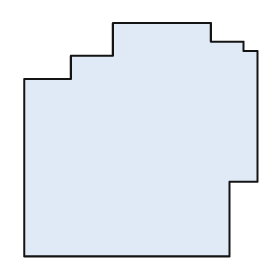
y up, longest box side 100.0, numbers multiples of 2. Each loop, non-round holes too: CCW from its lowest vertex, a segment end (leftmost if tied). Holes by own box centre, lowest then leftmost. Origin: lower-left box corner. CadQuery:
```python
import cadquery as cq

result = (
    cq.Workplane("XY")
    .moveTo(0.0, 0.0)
    .lineTo(88.0, 0.0)
    .lineTo(88.0, 32.0)
    .lineTo(100.0, 32.0)
    .lineTo(100.0, 88.0)
    .lineTo(94.0, 88.0)
    .lineTo(94.0, 92.0)
    .lineTo(80.0, 92.0)
    .lineTo(80.0, 100.0)
    .lineTo(38.0, 100.0)
    .lineTo(38.0, 86.0)
    .lineTo(20.0, 86.0)
    .lineTo(20.0, 76.0)
    .lineTo(0.0, 76.0)
    .close()
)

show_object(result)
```